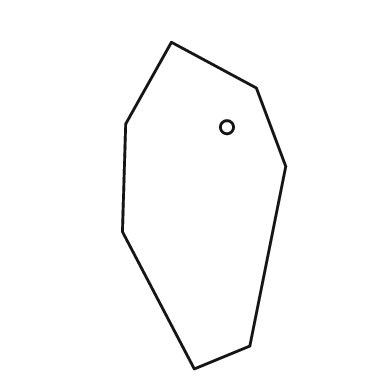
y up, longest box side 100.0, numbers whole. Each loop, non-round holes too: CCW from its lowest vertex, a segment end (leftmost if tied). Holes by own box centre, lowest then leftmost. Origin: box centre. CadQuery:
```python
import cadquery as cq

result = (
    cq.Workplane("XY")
    .moveTo(-3.0, -50.0)
    .lineTo(14.0, -43.0)
    .lineTo(25.0, 12.0)
    .lineTo(16.0, 36.0)
    .lineTo(-10.0, 50.0)
    .lineTo(-24.0, 25.0)
    .lineTo(-25.0, -8.0)
    .close()
    .moveTo(7.0, 24.0)
    .circle(2.0)
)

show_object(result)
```